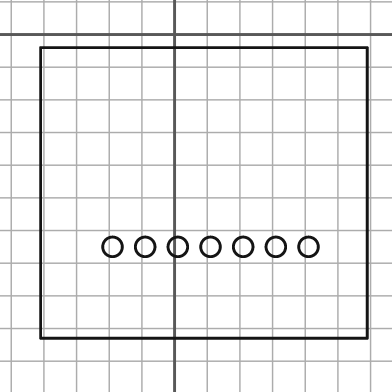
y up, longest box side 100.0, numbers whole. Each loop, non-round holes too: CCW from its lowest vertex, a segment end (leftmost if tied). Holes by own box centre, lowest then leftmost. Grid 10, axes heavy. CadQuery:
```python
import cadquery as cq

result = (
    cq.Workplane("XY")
    .moveTo(-41.0, -93.0)
    .lineTo(59.0, -93.0)
    .lineTo(59.0, -4.0)
    .lineTo(-41.0, -4.0)
    .close()
    .moveTo(-19.0, -65.0)
    .circle(3.0)
    .moveTo(-9.0, -65.0)
    .circle(3.0)
    .moveTo(1.0, -65.0)
    .circle(3.0)
    .moveTo(11.0, -65.0)
    .circle(3.0)
    .moveTo(21.0, -65.0)
    .circle(3.0)
    .moveTo(31.0, -65.0)
    .circle(3.0)
    .moveTo(41.0, -65.0)
    .circle(3.0)
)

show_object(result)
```